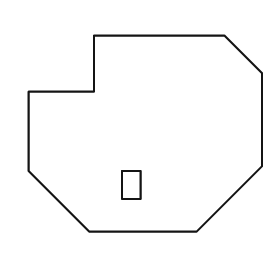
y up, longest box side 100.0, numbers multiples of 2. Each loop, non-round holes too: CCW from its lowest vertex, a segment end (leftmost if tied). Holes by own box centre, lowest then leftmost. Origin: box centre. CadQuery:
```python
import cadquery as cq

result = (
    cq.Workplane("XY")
    .moveTo(-24.0, -42.0)
    .lineTo(22.0, -42.0)
    .lineTo(50.0, -14.0)
    .lineTo(50.0, 26.0)
    .lineTo(34.0, 42.0)
    .lineTo(-22.0, 42.0)
    .lineTo(-22.0, 18.0)
    .lineTo(-50.0, 18.0)
    .lineTo(-50.0, -16.0)
    .close()
    .moveTo(-10.0, -28.0)
    .lineTo(-2.0, -28.0)
    .lineTo(-2.0, -16.0)
    .lineTo(-10.0, -16.0)
    .close()
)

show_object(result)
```